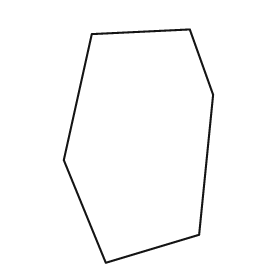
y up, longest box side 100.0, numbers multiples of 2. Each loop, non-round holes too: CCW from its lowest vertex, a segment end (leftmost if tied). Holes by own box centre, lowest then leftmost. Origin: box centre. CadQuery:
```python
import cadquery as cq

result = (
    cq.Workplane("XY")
    .moveTo(-14.0, -50.0)
    .lineTo(26.0, -38.0)
    .lineTo(32.0, 22.0)
    .lineTo(22.0, 50.0)
    .lineTo(-20.0, 48.0)
    .lineTo(-32.0, -6.0)
    .close()
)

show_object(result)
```